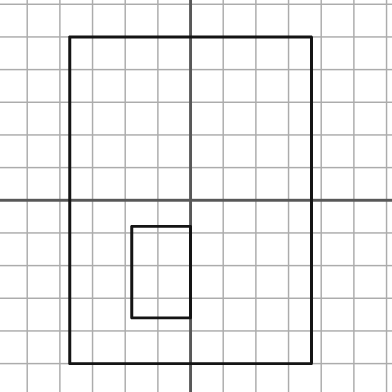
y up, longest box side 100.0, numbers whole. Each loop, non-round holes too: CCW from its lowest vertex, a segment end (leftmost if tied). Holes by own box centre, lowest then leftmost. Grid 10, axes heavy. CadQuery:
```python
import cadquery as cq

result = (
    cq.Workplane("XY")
    .moveTo(-37.0, -50.0)
    .lineTo(37.0, -50.0)
    .lineTo(37.0, 50.0)
    .lineTo(-37.0, 50.0)
    .close()
    .moveTo(-18.0, -36.0)
    .lineTo(0.0, -36.0)
    .lineTo(0.0, -8.0)
    .lineTo(-18.0, -8.0)
    .close()
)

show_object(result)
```